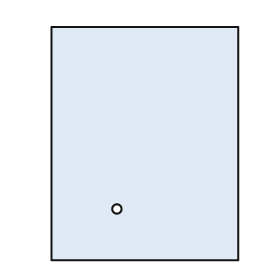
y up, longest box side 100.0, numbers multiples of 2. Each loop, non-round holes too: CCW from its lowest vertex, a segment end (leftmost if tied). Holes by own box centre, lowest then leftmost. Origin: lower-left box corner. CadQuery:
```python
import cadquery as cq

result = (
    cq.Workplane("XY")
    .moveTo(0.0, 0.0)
    .lineTo(80.0, 0.0)
    .lineTo(80.0, 100.0)
    .lineTo(0.0, 100.0)
    .close()
    .moveTo(28.0, 22.0)
    .circle(2.0)
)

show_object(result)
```